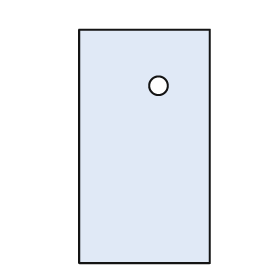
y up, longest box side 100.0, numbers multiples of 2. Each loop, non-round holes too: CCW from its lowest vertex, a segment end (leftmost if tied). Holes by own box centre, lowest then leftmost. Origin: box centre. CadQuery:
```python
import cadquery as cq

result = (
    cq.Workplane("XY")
    .moveTo(-28.0, -50.0)
    .lineTo(28.0, -50.0)
    .lineTo(28.0, 50.0)
    .lineTo(-28.0, 50.0)
    .close()
    .moveTo(6.0, 26.0)
    .circle(4.0)
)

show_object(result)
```